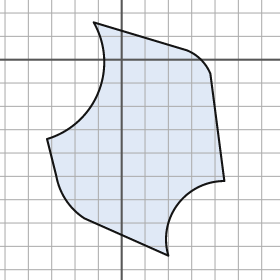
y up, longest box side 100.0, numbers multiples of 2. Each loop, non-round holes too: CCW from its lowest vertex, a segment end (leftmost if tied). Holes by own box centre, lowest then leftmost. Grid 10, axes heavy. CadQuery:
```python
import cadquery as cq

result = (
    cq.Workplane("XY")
    .moveTo(20.0, -84.0)
    .threePointArc((24.0, -62.0), (44.0, -52.0))
    .lineTo(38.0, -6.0)
    .threePointArc((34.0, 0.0), (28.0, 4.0))
    .lineTo(-12.0, 16.0)
    .threePointArc((-10.0, -14.0), (-32.0, -34.0))
    .lineTo(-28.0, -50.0)
    .threePointArc((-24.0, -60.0), (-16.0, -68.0))
    .close()
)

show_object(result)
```